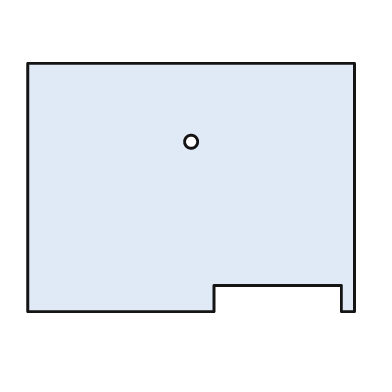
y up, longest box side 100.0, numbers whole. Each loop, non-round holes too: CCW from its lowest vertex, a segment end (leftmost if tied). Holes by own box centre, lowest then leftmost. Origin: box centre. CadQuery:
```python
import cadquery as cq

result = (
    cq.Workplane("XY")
    .moveTo(-50.0, -38.0)
    .lineTo(7.0, -38.0)
    .lineTo(7.0, -30.0)
    .lineTo(46.0, -30.0)
    .lineTo(46.0, -38.0)
    .lineTo(50.0, -38.0)
    .lineTo(50.0, 38.0)
    .lineTo(-50.0, 38.0)
    .close()
    .moveTo(0.0, 14.0)
    .circle(2.0)
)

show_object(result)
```